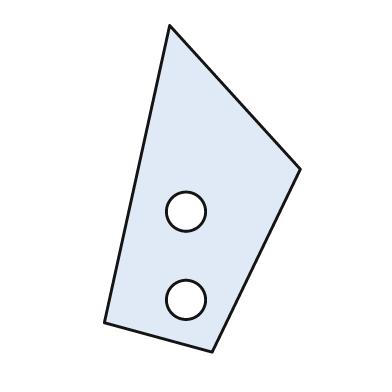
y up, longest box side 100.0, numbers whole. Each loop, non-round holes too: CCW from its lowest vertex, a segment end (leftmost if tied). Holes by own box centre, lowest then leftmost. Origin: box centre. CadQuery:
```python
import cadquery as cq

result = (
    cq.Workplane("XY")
    .moveTo(3.0, -50.0)
    .lineTo(30.0, 6.0)
    .lineTo(-10.0, 50.0)
    .lineTo(-30.0, -41.0)
    .close()
    .moveTo(-5.0, -34.0)
    .circle(6.0)
    .moveTo(-5.0, -7.0)
    .circle(6.0)
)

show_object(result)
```